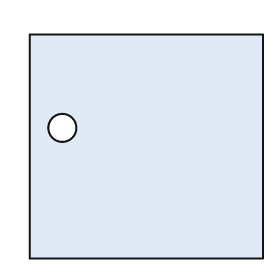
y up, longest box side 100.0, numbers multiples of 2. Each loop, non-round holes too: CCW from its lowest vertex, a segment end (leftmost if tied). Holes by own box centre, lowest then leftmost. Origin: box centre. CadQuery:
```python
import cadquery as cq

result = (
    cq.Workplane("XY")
    .moveTo(-50.0, -48.0)
    .lineTo(50.0, -48.0)
    .lineTo(50.0, 48.0)
    .lineTo(-50.0, 48.0)
    .close()
    .moveTo(-36.0, 8.0)
    .circle(6.0)
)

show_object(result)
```